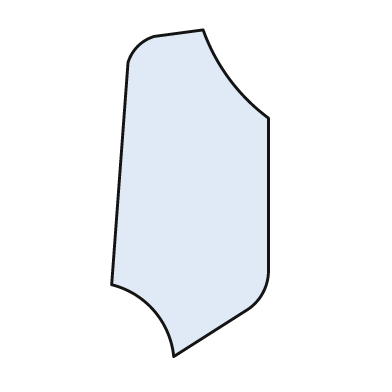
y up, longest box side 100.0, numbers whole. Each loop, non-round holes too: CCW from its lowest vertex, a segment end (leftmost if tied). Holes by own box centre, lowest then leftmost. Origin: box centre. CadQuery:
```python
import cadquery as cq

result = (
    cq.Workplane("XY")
    .moveTo(-5.0, -50.0)
    .lineTo(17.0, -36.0)
    .threePointArc((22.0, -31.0), (24.0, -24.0))
    .lineTo(24.0, 23.0)
    .threePointArc((12.0, 35.0), (4.0, 50.0))
    .lineTo(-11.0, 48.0)
    .threePointArc((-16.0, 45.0), (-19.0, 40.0))
    .lineTo(-24.0, -28.0)
    .threePointArc((-11.0, -36.0), (-5.0, -50.0))
    .close()
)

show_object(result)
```